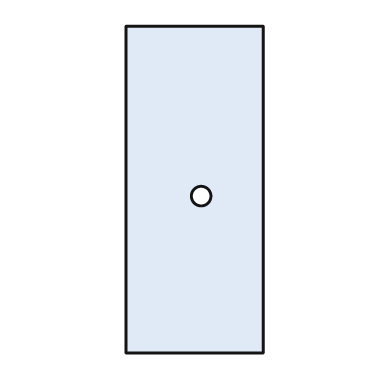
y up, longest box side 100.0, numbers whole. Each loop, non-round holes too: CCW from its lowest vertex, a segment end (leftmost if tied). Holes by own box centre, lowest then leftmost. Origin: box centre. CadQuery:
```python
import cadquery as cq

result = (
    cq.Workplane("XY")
    .moveTo(-21.0, -50.0)
    .lineTo(21.0, -50.0)
    .lineTo(21.0, 50.0)
    .lineTo(-21.0, 50.0)
    .close()
    .moveTo(2.0, -2.0)
    .circle(3.0)
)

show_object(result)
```